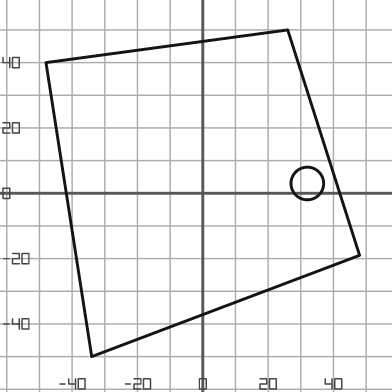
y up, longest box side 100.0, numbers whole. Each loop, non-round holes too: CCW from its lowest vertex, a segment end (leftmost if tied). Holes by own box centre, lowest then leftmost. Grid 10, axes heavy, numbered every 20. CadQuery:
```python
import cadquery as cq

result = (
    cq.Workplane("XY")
    .moveTo(-34.0, -50.0)
    .lineTo(48.0, -19.0)
    .lineTo(26.0, 50.0)
    .lineTo(-48.0, 40.0)
    .close()
    .moveTo(32.0, 3.0)
    .circle(5.0)
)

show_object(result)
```